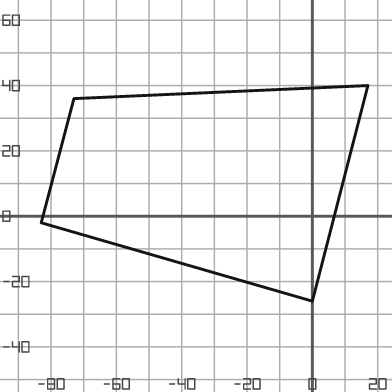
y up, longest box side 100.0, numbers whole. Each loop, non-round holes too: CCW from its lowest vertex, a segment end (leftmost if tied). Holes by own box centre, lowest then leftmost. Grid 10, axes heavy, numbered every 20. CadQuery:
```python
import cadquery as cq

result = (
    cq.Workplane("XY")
    .moveTo(0.0, -26.0)
    .lineTo(17.0, 40.0)
    .lineTo(-73.0, 36.0)
    .lineTo(-83.0, -2.0)
    .close()
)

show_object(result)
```